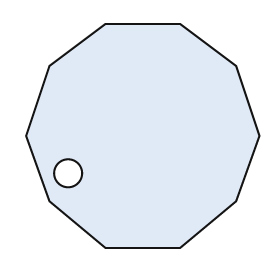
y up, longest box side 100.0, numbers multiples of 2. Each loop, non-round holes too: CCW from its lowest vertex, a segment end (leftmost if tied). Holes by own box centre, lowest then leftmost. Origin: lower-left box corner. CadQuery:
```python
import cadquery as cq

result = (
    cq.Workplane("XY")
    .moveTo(34.0, 0.0)
    .lineTo(66.0, 0.0)
    .lineTo(90.0, 20.0)
    .lineTo(100.0, 48.0)
    .lineTo(90.0, 78.0)
    .lineTo(66.0, 96.0)
    .lineTo(34.0, 96.0)
    .lineTo(10.0, 78.0)
    .lineTo(0.0, 48.0)
    .lineTo(10.0, 20.0)
    .close()
    .moveTo(18.0, 32.0)
    .circle(6.0)
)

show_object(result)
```